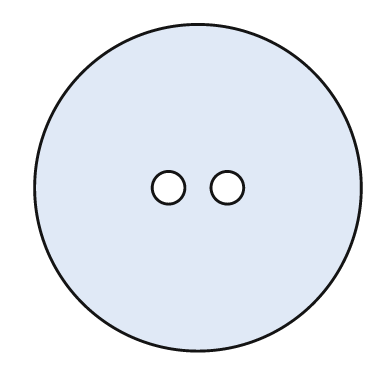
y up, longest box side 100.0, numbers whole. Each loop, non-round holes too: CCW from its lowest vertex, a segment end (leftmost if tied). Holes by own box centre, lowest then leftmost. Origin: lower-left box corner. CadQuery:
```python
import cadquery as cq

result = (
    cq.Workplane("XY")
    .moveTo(50.0, 50.0)
    .circle(50.0)
    .moveTo(41.0, 50.0)
    .circle(5.0)
    .moveTo(59.0, 50.0)
    .circle(5.0)
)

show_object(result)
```